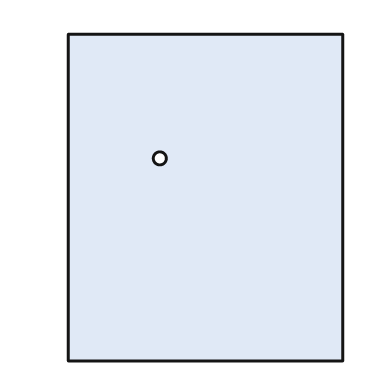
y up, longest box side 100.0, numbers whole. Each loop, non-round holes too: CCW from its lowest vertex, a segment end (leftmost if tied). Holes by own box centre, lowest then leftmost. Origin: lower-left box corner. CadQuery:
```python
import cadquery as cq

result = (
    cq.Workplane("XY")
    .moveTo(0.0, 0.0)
    .lineTo(84.0, 0.0)
    .lineTo(84.0, 100.0)
    .lineTo(0.0, 100.0)
    .close()
    .moveTo(28.0, 62.0)
    .circle(2.0)
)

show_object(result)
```